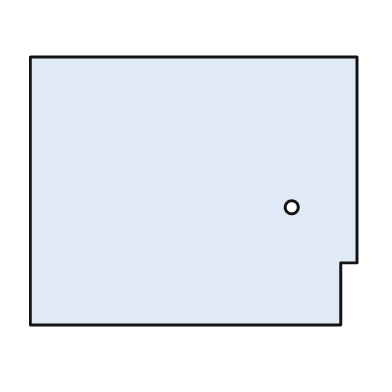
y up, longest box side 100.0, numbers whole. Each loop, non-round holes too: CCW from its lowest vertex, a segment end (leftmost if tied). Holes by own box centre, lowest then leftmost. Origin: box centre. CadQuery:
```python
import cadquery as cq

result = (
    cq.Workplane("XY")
    .moveTo(-50.0, -41.0)
    .lineTo(45.0, -41.0)
    .lineTo(45.0, -22.0)
    .lineTo(50.0, -22.0)
    .lineTo(50.0, 41.0)
    .lineTo(-50.0, 41.0)
    .close()
    .moveTo(30.0, -5.0)
    .circle(2.0)
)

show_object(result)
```